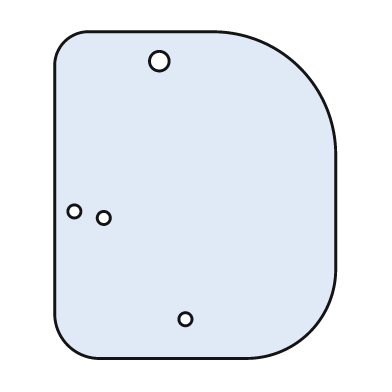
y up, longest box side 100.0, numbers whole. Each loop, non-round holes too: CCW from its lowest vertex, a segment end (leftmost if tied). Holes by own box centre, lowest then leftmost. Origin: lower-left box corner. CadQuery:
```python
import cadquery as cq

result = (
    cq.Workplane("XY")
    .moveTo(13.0, 0.0)
    .lineTo(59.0, 0.0)
    .threePointArc((78.0, 8.0), (86.0, 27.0))
    .lineTo(86.0, 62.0)
    .threePointArc((75.0, 89.0), (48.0, 100.0))
    .lineTo(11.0, 100.0)
    .threePointArc((3.0, 97.0), (0.0, 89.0))
    .lineTo(0.0, 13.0)
    .threePointArc((4.0, 4.0), (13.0, 0.0))
    .close()
    .moveTo(40.0, 12.0)
    .circle(2.0)
    .moveTo(15.0, 43.0)
    .circle(2.0)
    .moveTo(6.0, 45.0)
    .circle(2.0)
    .moveTo(32.0, 91.0)
    .circle(3.0)
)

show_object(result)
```